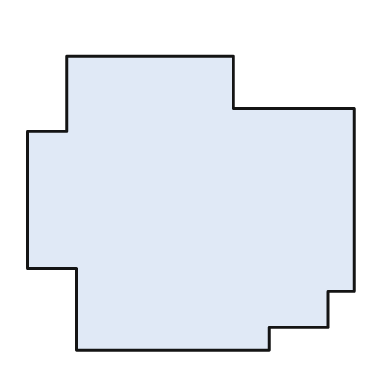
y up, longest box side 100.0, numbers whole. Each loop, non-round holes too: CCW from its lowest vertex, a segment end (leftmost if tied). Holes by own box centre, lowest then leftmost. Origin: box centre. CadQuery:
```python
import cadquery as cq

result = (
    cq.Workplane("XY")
    .moveTo(-35.0, -45.0)
    .lineTo(24.0, -45.0)
    .lineTo(24.0, -38.0)
    .lineTo(42.0, -38.0)
    .lineTo(42.0, -27.0)
    .lineTo(50.0, -27.0)
    .lineTo(50.0, 29.0)
    .lineTo(13.0, 29.0)
    .lineTo(13.0, 45.0)
    .lineTo(-38.0, 45.0)
    .lineTo(-38.0, 22.0)
    .lineTo(-50.0, 22.0)
    .lineTo(-50.0, -20.0)
    .lineTo(-35.0, -20.0)
    .close()
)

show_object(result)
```